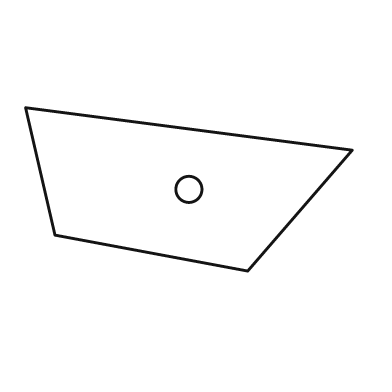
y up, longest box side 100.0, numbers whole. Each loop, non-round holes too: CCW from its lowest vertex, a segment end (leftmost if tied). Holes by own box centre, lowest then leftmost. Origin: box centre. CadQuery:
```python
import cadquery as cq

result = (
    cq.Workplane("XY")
    .moveTo(18.0, -25.0)
    .lineTo(50.0, 12.0)
    .lineTo(-50.0, 25.0)
    .lineTo(-41.0, -14.0)
    .close()
    .moveTo(0.0, 0.0)
    .circle(4.0)
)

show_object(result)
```